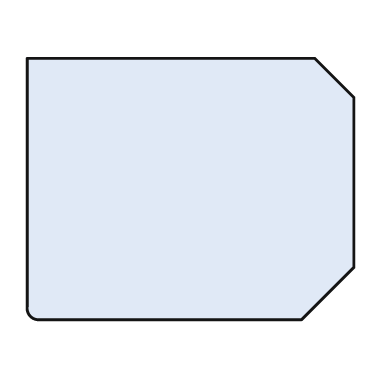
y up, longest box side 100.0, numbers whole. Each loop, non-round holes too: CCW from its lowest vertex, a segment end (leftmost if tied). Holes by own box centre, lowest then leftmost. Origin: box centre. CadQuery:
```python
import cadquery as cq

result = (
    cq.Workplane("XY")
    .moveTo(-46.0, -40.0)
    .lineTo(34.0, -40.0)
    .lineTo(50.0, -24.0)
    .lineTo(50.0, 28.0)
    .lineTo(38.0, 40.0)
    .lineTo(-50.0, 40.0)
    .lineTo(-50.0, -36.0)
    .threePointArc((-49.0, -39.0), (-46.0, -40.0))
    .close()
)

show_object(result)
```